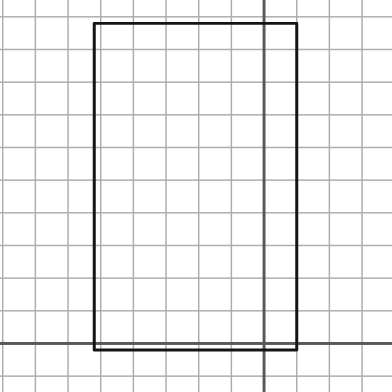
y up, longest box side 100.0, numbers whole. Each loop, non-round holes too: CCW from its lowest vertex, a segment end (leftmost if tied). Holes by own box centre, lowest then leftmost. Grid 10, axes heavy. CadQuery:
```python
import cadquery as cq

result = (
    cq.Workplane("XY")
    .moveTo(-52.0, -2.0)
    .lineTo(10.0, -2.0)
    .lineTo(10.0, 98.0)
    .lineTo(-52.0, 98.0)
    .close()
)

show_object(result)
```